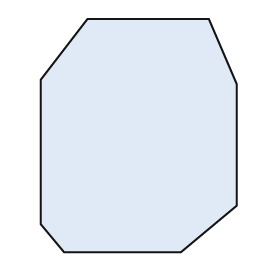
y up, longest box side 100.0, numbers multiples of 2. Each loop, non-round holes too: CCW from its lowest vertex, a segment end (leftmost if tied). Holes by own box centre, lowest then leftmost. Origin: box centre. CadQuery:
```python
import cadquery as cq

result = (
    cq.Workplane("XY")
    .moveTo(-32.0, -50.0)
    .lineTo(18.0, -50.0)
    .lineTo(42.0, -30.0)
    .lineTo(42.0, 22.0)
    .lineTo(30.0, 50.0)
    .lineTo(-22.0, 50.0)
    .lineTo(-42.0, 24.0)
    .lineTo(-42.0, -38.0)
    .close()
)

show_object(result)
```